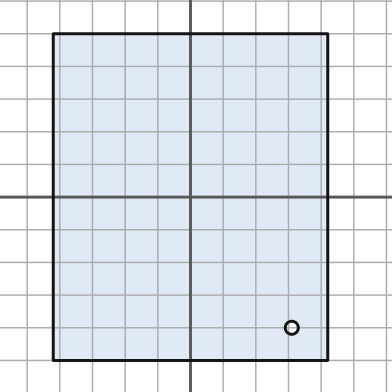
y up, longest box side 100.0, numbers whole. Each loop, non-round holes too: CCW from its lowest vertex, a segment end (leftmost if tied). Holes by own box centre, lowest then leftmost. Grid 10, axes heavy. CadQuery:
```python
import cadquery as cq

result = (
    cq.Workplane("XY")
    .moveTo(-42.0, -50.0)
    .lineTo(42.0, -50.0)
    .lineTo(42.0, 50.0)
    .lineTo(-42.0, 50.0)
    .close()
    .moveTo(31.0, -40.0)
    .circle(2.0)
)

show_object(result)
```